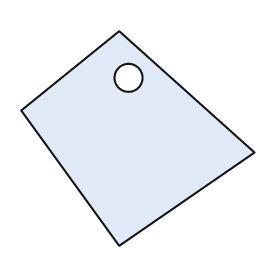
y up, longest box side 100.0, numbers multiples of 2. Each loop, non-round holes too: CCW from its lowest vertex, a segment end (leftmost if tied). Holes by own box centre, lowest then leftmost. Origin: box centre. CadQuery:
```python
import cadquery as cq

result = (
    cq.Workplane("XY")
    .moveTo(-8.0, -46.0)
    .lineTo(50.0, -6.0)
    .lineTo(-8.0, 46.0)
    .lineTo(-50.0, 12.0)
    .close()
    .moveTo(-4.0, 26.0)
    .circle(6.0)
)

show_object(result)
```